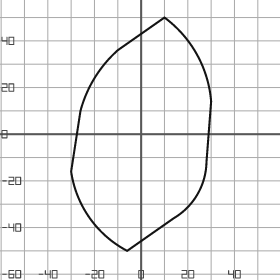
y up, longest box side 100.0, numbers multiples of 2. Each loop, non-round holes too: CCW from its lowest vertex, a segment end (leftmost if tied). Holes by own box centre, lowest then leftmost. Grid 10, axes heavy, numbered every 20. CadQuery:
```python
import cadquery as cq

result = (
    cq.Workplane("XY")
    .moveTo(-6.0, -50.0)
    .lineTo(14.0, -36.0)
    .threePointArc((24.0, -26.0), (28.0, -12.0))
    .lineTo(30.0, 14.0)
    .threePointArc((24.0, 34.0), (10.0, 50.0))
    .lineTo(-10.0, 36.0)
    .threePointArc((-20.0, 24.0), (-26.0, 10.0))
    .lineTo(-30.0, -16.0)
    .threePointArc((-22.0, -36.0), (-6.0, -50.0))
    .close()
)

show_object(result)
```